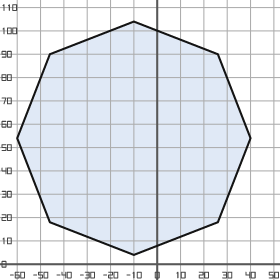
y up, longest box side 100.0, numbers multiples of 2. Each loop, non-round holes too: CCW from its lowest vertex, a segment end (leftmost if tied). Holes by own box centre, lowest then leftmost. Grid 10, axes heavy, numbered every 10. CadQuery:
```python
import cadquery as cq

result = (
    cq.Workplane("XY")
    .moveTo(-10.0, 4.0)
    .lineTo(26.0, 18.0)
    .lineTo(40.0, 54.0)
    .lineTo(26.0, 90.0)
    .lineTo(-10.0, 104.0)
    .lineTo(-46.0, 90.0)
    .lineTo(-60.0, 54.0)
    .lineTo(-46.0, 18.0)
    .close()
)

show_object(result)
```